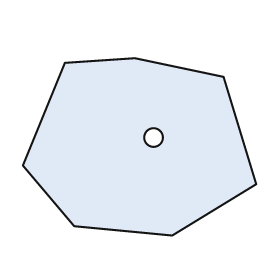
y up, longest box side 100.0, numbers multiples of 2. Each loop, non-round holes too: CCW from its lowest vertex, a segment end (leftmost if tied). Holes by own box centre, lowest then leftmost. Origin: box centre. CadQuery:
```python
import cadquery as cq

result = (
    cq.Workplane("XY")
    .moveTo(14.0, -38.0)
    .lineTo(50.0, -16.0)
    .lineTo(36.0, 30.0)
    .lineTo(-2.0, 38.0)
    .lineTo(-32.0, 36.0)
    .lineTo(-50.0, -8.0)
    .lineTo(-28.0, -34.0)
    .close()
    .moveTo(6.0, 4.0)
    .circle(4.0)
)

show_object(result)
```